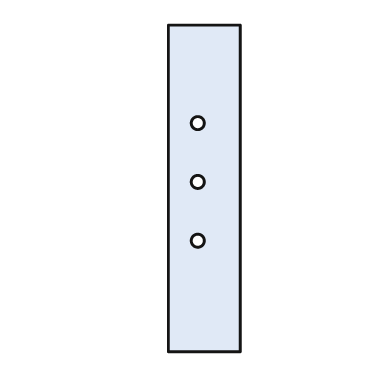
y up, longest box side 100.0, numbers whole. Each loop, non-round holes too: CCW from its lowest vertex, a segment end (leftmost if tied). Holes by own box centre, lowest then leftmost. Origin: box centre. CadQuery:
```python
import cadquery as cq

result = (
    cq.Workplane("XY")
    .moveTo(-11.0, -50.0)
    .lineTo(11.0, -50.0)
    .lineTo(11.0, 50.0)
    .lineTo(-11.0, 50.0)
    .close()
    .moveTo(-2.0, -16.0)
    .circle(2.0)
    .moveTo(-2.0, 2.0)
    .circle(2.0)
    .moveTo(-2.0, 20.0)
    .circle(2.0)
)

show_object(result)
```